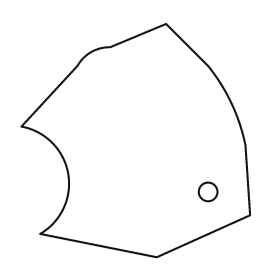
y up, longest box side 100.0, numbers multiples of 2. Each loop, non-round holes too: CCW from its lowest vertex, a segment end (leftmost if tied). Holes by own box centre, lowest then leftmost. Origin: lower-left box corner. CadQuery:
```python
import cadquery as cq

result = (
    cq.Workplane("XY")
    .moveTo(58.0, 0.0)
    .lineTo(98.0, 18.0)
    .lineTo(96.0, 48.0)
    .threePointArc((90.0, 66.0), (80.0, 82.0))
    .lineTo(62.0, 100.0)
    .lineTo(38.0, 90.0)
    .threePointArc((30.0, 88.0), (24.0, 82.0))
    .lineTo(0.0, 56.0)
    .threePointArc((20.0, 36.0), (8.0, 10.0))
    .close()
    .moveTo(80.0, 28.0)
    .circle(4.0)
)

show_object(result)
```